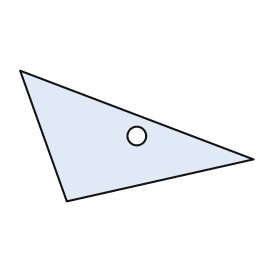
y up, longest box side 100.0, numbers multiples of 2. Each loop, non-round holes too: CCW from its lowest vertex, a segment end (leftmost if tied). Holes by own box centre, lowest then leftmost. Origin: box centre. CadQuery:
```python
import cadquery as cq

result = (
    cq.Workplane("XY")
    .moveTo(-30.0, -28.0)
    .lineTo(50.0, -10.0)
    .lineTo(-50.0, 28.0)
    .close()
    .moveTo(0.0, 0.0)
    .circle(4.0)
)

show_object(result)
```